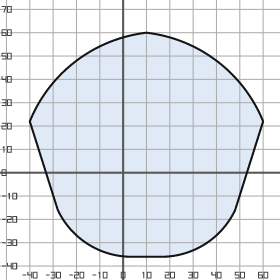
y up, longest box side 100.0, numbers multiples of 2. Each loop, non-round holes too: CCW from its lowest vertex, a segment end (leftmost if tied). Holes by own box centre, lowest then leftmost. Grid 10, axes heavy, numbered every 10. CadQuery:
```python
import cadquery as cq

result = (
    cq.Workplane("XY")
    .moveTo(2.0, -36.0)
    .lineTo(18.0, -36.0)
    .threePointArc((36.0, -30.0), (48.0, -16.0))
    .lineTo(60.0, 22.0)
    .threePointArc((40.0, 48.0), (10.0, 60.0))
    .threePointArc((-20.0, 48.0), (-40.0, 22.0))
    .lineTo(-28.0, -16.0)
    .threePointArc((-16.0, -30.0), (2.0, -36.0))
    .close()
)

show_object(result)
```